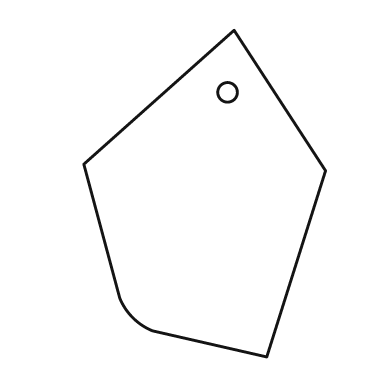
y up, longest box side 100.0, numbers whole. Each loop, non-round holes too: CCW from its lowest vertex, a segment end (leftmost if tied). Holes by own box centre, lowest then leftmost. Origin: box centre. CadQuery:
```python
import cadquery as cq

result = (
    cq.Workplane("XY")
    .moveTo(19.0, -50.0)
    .lineTo(37.0, 7.0)
    .lineTo(9.0, 50.0)
    .lineTo(-37.0, 9.0)
    .lineTo(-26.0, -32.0)
    .threePointArc((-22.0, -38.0), (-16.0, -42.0))
    .close()
    .moveTo(7.0, 31.0)
    .circle(3.0)
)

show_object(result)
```